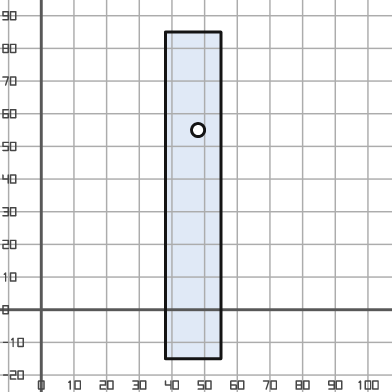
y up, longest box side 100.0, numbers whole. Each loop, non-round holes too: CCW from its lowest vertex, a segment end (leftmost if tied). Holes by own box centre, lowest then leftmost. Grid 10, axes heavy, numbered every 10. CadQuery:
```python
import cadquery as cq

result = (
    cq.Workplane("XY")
    .moveTo(38.0, -15.0)
    .lineTo(55.0, -15.0)
    .lineTo(55.0, 85.0)
    .lineTo(38.0, 85.0)
    .close()
    .moveTo(48.0, 55.0)
    .circle(2.0)
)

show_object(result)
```